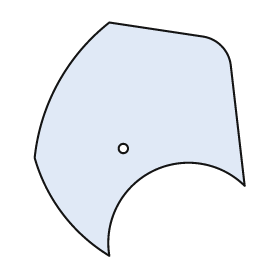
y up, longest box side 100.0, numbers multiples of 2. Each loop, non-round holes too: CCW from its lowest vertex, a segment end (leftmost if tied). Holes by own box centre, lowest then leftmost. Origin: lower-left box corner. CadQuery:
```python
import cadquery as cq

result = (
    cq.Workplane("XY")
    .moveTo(32.0, 0.0)
    .threePointArc((50.0, 36.0), (90.0, 30.0))
    .lineTo(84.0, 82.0)
    .threePointArc((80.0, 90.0), (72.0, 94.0))
    .lineTo(32.0, 100.0)
    .threePointArc((10.0, 74.0), (0.0, 42.0))
    .threePointArc((12.0, 18.0), (32.0, 0.0))
    .close()
    .moveTo(38.0, 46.0)
    .circle(2.0)
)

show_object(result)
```